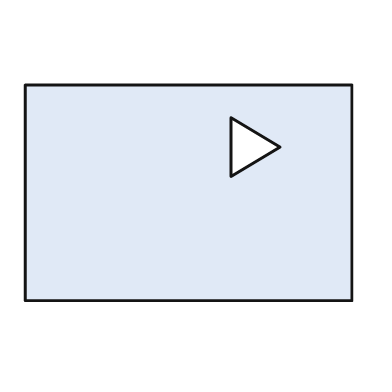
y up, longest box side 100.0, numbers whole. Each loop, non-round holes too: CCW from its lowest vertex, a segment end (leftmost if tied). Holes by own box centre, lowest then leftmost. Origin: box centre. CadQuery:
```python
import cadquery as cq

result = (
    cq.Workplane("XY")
    .moveTo(-50.0, -33.0)
    .lineTo(50.0, -33.0)
    .lineTo(50.0, 33.0)
    .lineTo(-50.0, 33.0)
    .close()
    .moveTo(13.0, 5.0)
    .lineTo(28.0, 14.0)
    .lineTo(13.0, 23.0)
    .close()
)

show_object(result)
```